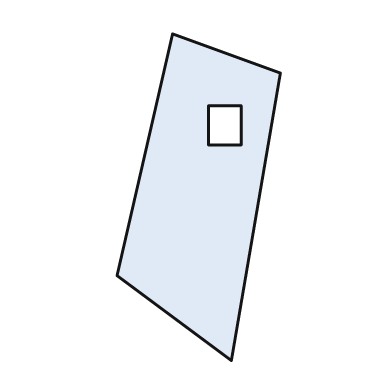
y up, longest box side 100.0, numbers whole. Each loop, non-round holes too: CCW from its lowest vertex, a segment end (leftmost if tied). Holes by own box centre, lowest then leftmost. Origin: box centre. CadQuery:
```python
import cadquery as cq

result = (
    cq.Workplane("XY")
    .moveTo(10.0, -50.0)
    .lineTo(25.0, 38.0)
    .lineTo(-8.0, 50.0)
    .lineTo(-25.0, -24.0)
    .close()
    .moveTo(3.0, 16.0)
    .lineTo(13.0, 16.0)
    .lineTo(13.0, 28.0)
    .lineTo(3.0, 28.0)
    .close()
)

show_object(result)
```